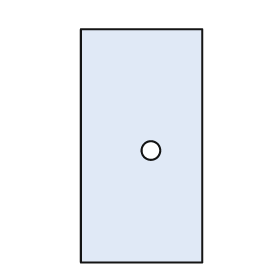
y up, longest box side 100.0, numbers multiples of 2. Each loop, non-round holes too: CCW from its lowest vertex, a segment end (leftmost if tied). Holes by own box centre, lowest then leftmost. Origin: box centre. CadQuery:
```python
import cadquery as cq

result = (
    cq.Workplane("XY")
    .moveTo(-26.0, -50.0)
    .lineTo(26.0, -50.0)
    .lineTo(26.0, 50.0)
    .lineTo(-26.0, 50.0)
    .close()
    .moveTo(4.0, -2.0)
    .circle(4.0)
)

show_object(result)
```